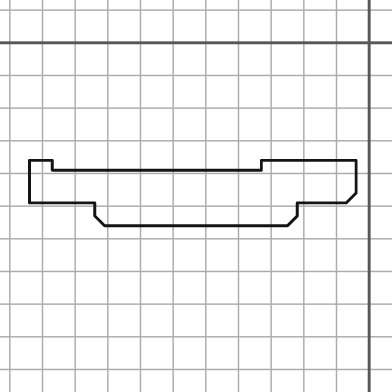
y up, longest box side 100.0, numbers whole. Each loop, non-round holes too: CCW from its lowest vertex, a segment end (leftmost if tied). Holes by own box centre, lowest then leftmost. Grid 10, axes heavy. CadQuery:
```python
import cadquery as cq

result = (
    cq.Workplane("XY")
    .moveTo(-81.0, -56.0)
    .lineTo(-25.0, -56.0)
    .lineTo(-22.0, -53.0)
    .lineTo(-22.0, -49.0)
    .lineTo(-7.0, -49.0)
    .lineTo(-4.0, -46.0)
    .lineTo(-4.0, -36.0)
    .lineTo(-33.0, -36.0)
    .lineTo(-33.0, -39.0)
    .lineTo(-97.0, -39.0)
    .lineTo(-97.0, -36.0)
    .lineTo(-104.0, -36.0)
    .lineTo(-104.0, -49.0)
    .lineTo(-84.0, -49.0)
    .lineTo(-84.0, -53.0)
    .close()
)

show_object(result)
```